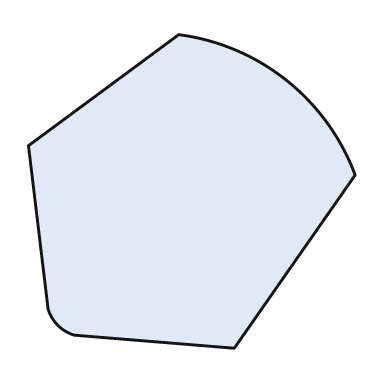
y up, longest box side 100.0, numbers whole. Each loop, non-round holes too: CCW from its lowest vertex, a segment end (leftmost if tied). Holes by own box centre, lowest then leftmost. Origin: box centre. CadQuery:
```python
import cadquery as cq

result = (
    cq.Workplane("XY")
    .moveTo(13.0, -48.0)
    .lineTo(50.0, 5.0)
    .threePointArc((29.0, 34.0), (-4.0, 48.0))
    .lineTo(-50.0, 14.0)
    .lineTo(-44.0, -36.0)
    .threePointArc((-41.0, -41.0), (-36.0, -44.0))
    .close()
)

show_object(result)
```